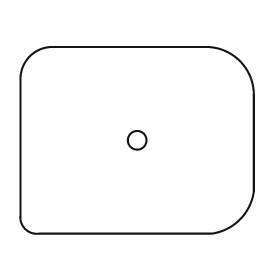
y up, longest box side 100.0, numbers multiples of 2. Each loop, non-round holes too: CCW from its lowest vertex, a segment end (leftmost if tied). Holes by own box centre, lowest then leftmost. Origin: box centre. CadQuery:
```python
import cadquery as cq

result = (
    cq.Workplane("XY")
    .moveTo(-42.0, -40.0)
    .lineTo(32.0, -40.0)
    .threePointArc((44.0, -34.0), (50.0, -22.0))
    .lineTo(50.0, 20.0)
    .threePointArc((44.0, 34.0), (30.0, 40.0))
    .lineTo(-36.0, 40.0)
    .threePointArc((-46.0, 36.0), (-50.0, 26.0))
    .lineTo(-50.0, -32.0)
    .threePointArc((-48.0, -38.0), (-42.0, -40.0))
    .close()
    .moveTo(0.0, 0.0)
    .circle(4.0)
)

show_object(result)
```